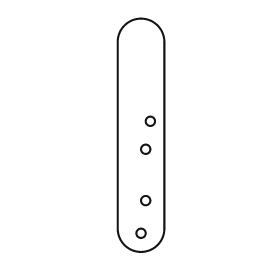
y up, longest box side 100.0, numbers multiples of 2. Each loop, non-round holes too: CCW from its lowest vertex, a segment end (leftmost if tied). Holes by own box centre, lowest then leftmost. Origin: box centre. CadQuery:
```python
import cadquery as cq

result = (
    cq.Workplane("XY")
    .moveTo(-10.0, -40.0)
    .threePointArc((0.0, -50.0), (10.0, -40.0))
    .lineTo(10.0, 40.0)
    .threePointArc((0.0, 50.0), (-10.0, 40.0))
    .close()
    .moveTo(0.0, -42.0)
    .circle(2.0)
    .moveTo(2.0, -28.0)
    .circle(2.0)
    .moveTo(2.0, -6.0)
    .circle(2.0)
    .moveTo(4.0, 6.0)
    .circle(2.0)
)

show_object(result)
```